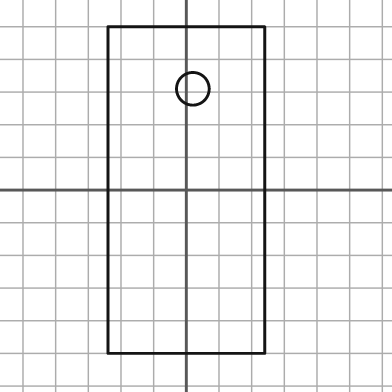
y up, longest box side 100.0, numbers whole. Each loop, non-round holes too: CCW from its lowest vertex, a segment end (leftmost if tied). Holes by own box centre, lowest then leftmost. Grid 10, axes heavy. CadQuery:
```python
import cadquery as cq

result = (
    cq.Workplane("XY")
    .moveTo(-24.0, -50.0)
    .lineTo(24.0, -50.0)
    .lineTo(24.0, 50.0)
    .lineTo(-24.0, 50.0)
    .close()
    .moveTo(2.0, 31.0)
    .circle(5.0)
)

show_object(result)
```